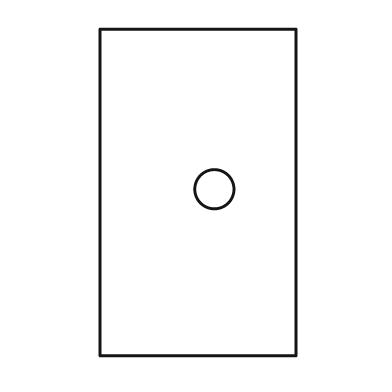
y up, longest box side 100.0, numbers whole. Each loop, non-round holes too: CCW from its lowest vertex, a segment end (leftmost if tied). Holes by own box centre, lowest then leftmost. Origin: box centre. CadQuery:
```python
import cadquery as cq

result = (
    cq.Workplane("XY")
    .moveTo(-30.0, -50.0)
    .lineTo(30.0, -50.0)
    .lineTo(30.0, 50.0)
    .lineTo(-30.0, 50.0)
    .close()
    .moveTo(5.0, 1.0)
    .circle(6.0)
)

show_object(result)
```